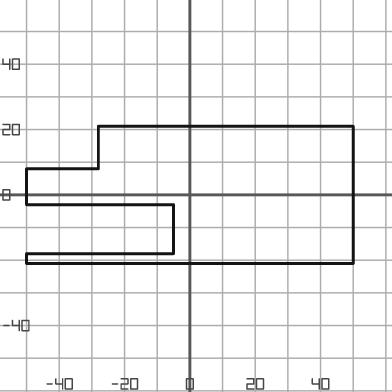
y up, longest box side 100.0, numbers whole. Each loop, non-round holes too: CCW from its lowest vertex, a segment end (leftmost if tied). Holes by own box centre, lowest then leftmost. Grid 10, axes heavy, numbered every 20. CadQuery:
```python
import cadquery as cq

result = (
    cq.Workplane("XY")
    .moveTo(-50.0, -21.0)
    .lineTo(50.0, -21.0)
    .lineTo(50.0, 21.0)
    .lineTo(-28.0, 21.0)
    .lineTo(-28.0, 8.0)
    .lineTo(-50.0, 8.0)
    .lineTo(-50.0, -3.0)
    .lineTo(-5.0, -3.0)
    .lineTo(-5.0, -18.0)
    .lineTo(-50.0, -18.0)
    .close()
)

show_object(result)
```